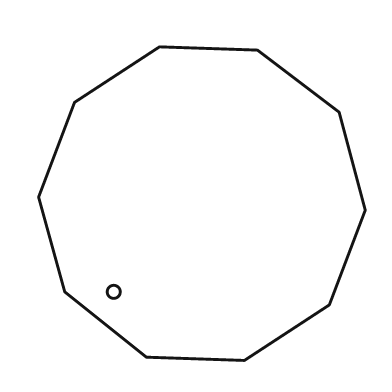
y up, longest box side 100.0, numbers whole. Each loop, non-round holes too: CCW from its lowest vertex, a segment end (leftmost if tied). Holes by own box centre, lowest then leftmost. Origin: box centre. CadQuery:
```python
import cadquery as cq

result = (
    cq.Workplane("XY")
    .moveTo(13.0, -48.0)
    .lineTo(39.0, -31.0)
    .lineTo(50.0, -2.0)
    .lineTo(42.0, 28.0)
    .lineTo(17.0, 47.0)
    .lineTo(-13.0, 48.0)
    .lineTo(-39.0, 31.0)
    .lineTo(-50.0, 2.0)
    .lineTo(-42.0, -27.0)
    .lineTo(-17.0, -47.0)
    .close()
    .moveTo(-27.0, -27.0)
    .circle(2.0)
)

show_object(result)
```